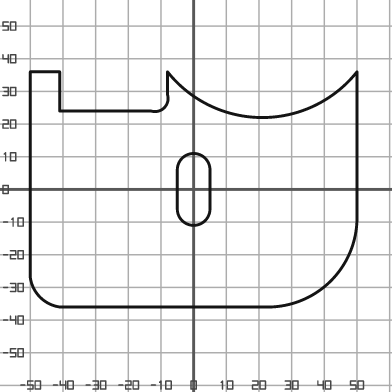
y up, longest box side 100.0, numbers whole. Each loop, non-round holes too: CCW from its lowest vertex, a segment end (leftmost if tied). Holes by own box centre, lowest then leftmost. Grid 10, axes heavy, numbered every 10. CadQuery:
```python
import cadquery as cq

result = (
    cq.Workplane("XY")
    .moveTo(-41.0, -36.0)
    .lineTo(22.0, -36.0)
    .threePointArc((42.0, -28.0), (50.0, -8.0))
    .lineTo(50.0, 36.0)
    .threePointArc((21.0, 22.0), (-8.0, 36.0))
    .lineTo(-8.0, 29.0)
    .threePointArc((-9.0, 25.0), (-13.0, 24.0))
    .lineTo(-41.0, 24.0)
    .lineTo(-41.0, 36.0)
    .lineTo(-50.0, 36.0)
    .lineTo(-50.0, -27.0)
    .threePointArc((-47.0, -33.0), (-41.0, -36.0))
    .close()
    .moveTo(-5.0, -6.0)
    .threePointArc((0.0, -11.0), (5.0, -6.0))
    .lineTo(5.0, 6.0)
    .threePointArc((0.0, 11.0), (-5.0, 6.0))
    .close()
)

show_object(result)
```